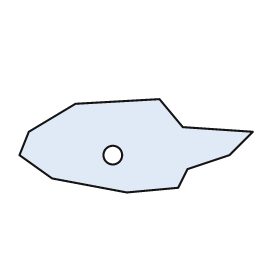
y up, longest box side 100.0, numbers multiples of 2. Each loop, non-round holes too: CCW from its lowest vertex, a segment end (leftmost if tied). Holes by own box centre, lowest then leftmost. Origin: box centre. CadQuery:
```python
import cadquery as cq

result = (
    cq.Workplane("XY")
    .moveTo(-4.0, -20.0)
    .lineTo(18.0, -18.0)
    .lineTo(22.0, -10.0)
    .lineTo(40.0, -4.0)
    .lineTo(50.0, 6.0)
    .lineTo(20.0, 8.0)
    .lineTo(10.0, 20.0)
    .lineTo(-26.0, 18.0)
    .lineTo(-46.0, 6.0)
    .lineTo(-50.0, -4.0)
    .lineTo(-36.0, -14.0)
    .close()
    .moveTo(-10.0, -4.0)
    .circle(4.0)
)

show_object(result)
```